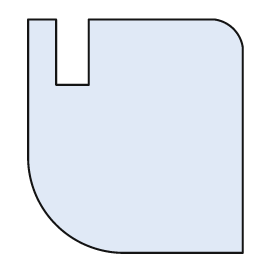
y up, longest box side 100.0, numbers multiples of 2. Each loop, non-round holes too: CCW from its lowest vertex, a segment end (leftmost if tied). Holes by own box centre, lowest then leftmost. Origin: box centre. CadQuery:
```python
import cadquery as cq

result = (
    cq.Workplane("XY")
    .moveTo(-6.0, -50.0)
    .lineTo(46.0, -50.0)
    .lineTo(46.0, 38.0)
    .threePointArc((42.0, 46.0), (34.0, 50.0))
    .lineTo(-20.0, 50.0)
    .lineTo(-20.0, 22.0)
    .lineTo(-34.0, 22.0)
    .lineTo(-34.0, 50.0)
    .lineTo(-46.0, 50.0)
    .lineTo(-46.0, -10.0)
    .threePointArc((-34.0, -38.0), (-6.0, -50.0))
    .close()
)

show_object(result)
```